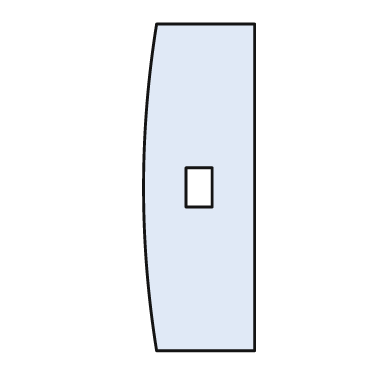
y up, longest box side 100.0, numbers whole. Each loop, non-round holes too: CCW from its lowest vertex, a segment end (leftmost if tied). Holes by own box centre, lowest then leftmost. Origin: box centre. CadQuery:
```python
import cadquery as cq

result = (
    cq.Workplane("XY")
    .moveTo(-13.0, -50.0)
    .lineTo(17.0, -50.0)
    .lineTo(17.0, 50.0)
    .lineTo(-13.0, 50.0)
    .threePointArc((-17.0, 0.0), (-13.0, -50.0))
    .close()
    .moveTo(-4.0, -6.0)
    .lineTo(4.0, -6.0)
    .lineTo(4.0, 6.0)
    .lineTo(-4.0, 6.0)
    .close()
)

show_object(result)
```